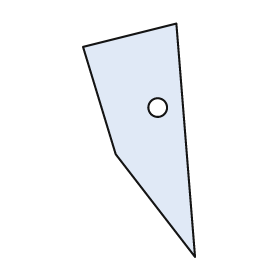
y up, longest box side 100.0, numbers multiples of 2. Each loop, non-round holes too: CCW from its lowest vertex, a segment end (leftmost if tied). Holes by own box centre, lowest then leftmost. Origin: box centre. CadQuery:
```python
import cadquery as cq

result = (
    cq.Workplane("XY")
    .moveTo(24.0, -50.0)
    .lineTo(16.0, 50.0)
    .lineTo(-24.0, 40.0)
    .lineTo(-10.0, -6.0)
    .close()
    .moveTo(8.0, 14.0)
    .circle(4.0)
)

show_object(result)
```